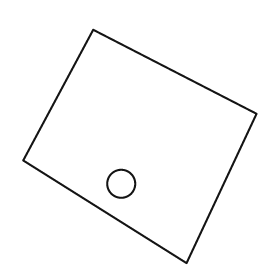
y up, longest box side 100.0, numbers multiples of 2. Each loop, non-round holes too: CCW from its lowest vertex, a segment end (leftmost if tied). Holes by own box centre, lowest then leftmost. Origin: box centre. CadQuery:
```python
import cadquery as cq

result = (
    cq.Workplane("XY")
    .moveTo(20.0, -50.0)
    .lineTo(50.0, 14.0)
    .lineTo(-20.0, 50.0)
    .lineTo(-50.0, -6.0)
    .close()
    .moveTo(-8.0, -16.0)
    .circle(6.0)
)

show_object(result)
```